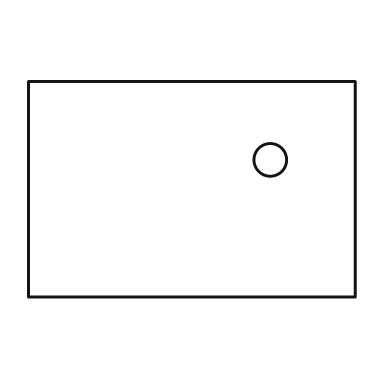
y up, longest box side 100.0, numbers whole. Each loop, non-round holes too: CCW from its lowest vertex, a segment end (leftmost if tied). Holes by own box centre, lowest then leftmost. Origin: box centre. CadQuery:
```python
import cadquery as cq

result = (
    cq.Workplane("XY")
    .moveTo(-50.0, -33.0)
    .lineTo(50.0, -33.0)
    .lineTo(50.0, 33.0)
    .lineTo(-50.0, 33.0)
    .close()
    .moveTo(24.0, 9.0)
    .circle(5.0)
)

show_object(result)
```